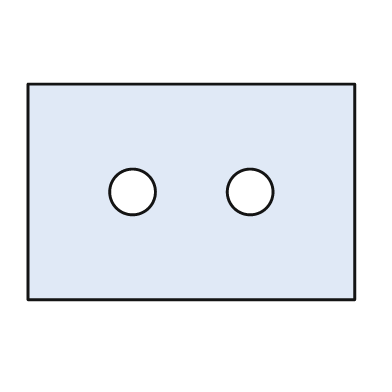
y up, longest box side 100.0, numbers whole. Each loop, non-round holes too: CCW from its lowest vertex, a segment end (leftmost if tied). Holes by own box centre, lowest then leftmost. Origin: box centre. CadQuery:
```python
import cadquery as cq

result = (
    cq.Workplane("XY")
    .moveTo(-50.0, -33.0)
    .lineTo(50.0, -33.0)
    .lineTo(50.0, 33.0)
    .lineTo(-50.0, 33.0)
    .close()
    .moveTo(-18.0, 0.0)
    .circle(7.0)
    .moveTo(18.0, 0.0)
    .circle(7.0)
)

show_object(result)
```